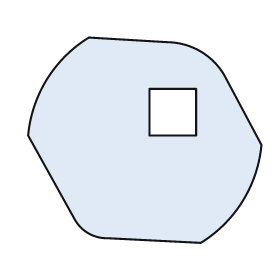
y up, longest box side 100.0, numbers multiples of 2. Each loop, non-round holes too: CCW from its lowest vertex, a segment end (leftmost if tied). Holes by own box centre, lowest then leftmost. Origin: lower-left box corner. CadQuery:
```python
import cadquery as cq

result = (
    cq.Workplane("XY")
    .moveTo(74.0, 0.0)
    .threePointArc((92.0, 18.0), (100.0, 42.0))
    .lineTo(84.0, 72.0)
    .threePointArc((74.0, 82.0), (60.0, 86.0))
    .lineTo(26.0, 88.0)
    .threePointArc((8.0, 70.0), (0.0, 46.0))
    .lineTo(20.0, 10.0)
    .threePointArc((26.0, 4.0), (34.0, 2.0))
    .close()
    .moveTo(52.0, 46.0)
    .lineTo(72.0, 46.0)
    .lineTo(72.0, 66.0)
    .lineTo(52.0, 66.0)
    .close()
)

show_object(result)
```